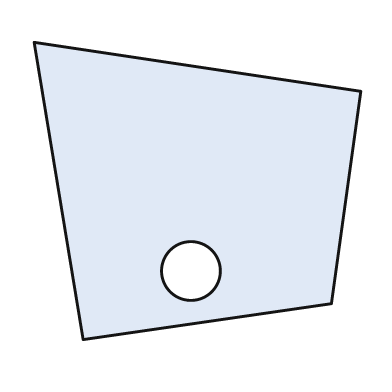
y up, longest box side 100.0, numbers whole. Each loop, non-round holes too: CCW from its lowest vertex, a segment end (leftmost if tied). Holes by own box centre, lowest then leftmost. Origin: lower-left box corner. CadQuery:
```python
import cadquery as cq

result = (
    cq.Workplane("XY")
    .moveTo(15.0, 0.0)
    .lineTo(91.0, 11.0)
    .lineTo(100.0, 76.0)
    .lineTo(0.0, 91.0)
    .close()
    .moveTo(48.0, 21.0)
    .circle(9.0)
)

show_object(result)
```